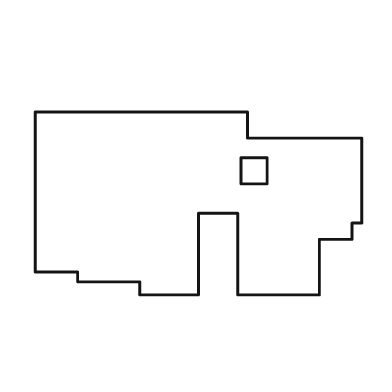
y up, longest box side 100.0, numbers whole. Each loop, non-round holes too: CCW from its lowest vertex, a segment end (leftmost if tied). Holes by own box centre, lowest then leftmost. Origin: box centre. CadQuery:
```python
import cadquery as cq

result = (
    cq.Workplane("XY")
    .moveTo(-18.0, -28.0)
    .lineTo(0.0, -28.0)
    .lineTo(0.0, -3.0)
    .lineTo(12.0, -3.0)
    .lineTo(12.0, -28.0)
    .lineTo(37.0, -28.0)
    .lineTo(37.0, -11.0)
    .lineTo(47.0, -11.0)
    .lineTo(47.0, -6.0)
    .lineTo(50.0, -6.0)
    .lineTo(50.0, 20.0)
    .lineTo(15.0, 20.0)
    .lineTo(15.0, 28.0)
    .lineTo(-50.0, 28.0)
    .lineTo(-50.0, -21.0)
    .lineTo(-37.0, -21.0)
    .lineTo(-37.0, -24.0)
    .lineTo(-18.0, -24.0)
    .close()
    .moveTo(13.0, 6.0)
    .lineTo(21.0, 6.0)
    .lineTo(21.0, 14.0)
    .lineTo(13.0, 14.0)
    .close()
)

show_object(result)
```